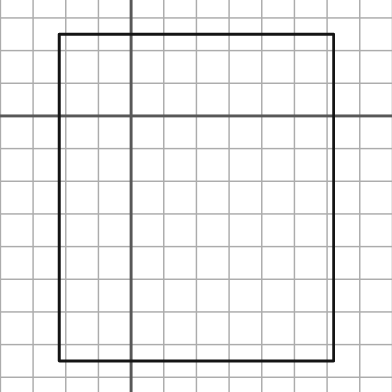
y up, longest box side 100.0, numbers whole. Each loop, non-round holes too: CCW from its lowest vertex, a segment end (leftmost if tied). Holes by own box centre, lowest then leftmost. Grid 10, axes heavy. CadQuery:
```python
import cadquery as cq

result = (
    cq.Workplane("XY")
    .moveTo(-22.0, -75.0)
    .lineTo(62.0, -75.0)
    .lineTo(62.0, 25.0)
    .lineTo(-22.0, 25.0)
    .close()
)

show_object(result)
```